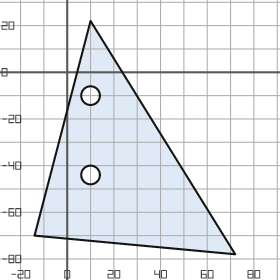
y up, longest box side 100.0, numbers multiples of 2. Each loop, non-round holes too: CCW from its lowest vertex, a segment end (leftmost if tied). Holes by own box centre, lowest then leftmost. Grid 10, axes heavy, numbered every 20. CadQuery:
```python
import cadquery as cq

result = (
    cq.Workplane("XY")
    .moveTo(72.0, -78.0)
    .lineTo(10.0, 22.0)
    .lineTo(-14.0, -70.0)
    .close()
    .moveTo(10.0, -44.0)
    .circle(4.0)
    .moveTo(10.0, -10.0)
    .circle(4.0)
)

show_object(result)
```